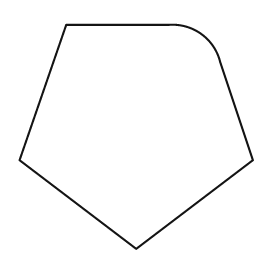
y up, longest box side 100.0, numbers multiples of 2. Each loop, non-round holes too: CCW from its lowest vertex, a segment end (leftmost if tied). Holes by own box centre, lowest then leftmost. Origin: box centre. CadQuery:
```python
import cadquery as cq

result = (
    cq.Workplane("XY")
    .moveTo(0.0, -48.0)
    .lineTo(50.0, -10.0)
    .lineTo(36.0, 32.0)
    .threePointArc((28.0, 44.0), (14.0, 48.0))
    .lineTo(-30.0, 48.0)
    .lineTo(-50.0, -10.0)
    .close()
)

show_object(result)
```